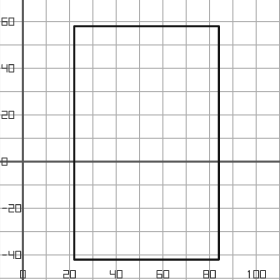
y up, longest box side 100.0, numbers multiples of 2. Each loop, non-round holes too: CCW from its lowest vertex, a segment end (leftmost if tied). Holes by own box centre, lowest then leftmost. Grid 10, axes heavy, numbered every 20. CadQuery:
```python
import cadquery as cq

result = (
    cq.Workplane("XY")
    .moveTo(22.0, -42.0)
    .lineTo(84.0, -42.0)
    .lineTo(84.0, 58.0)
    .lineTo(22.0, 58.0)
    .close()
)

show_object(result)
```